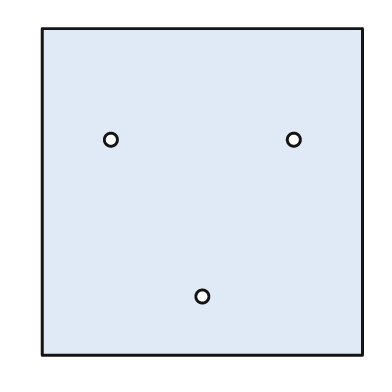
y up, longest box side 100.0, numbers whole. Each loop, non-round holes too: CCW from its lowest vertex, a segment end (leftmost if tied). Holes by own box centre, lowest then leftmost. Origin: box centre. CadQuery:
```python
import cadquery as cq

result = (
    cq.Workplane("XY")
    .moveTo(-49.0, -50.0)
    .lineTo(49.0, -50.0)
    .lineTo(49.0, 50.0)
    .lineTo(-49.0, 50.0)
    .close()
    .moveTo(0.0, -32.0)
    .circle(2.0)
    .moveTo(-28.0, 16.0)
    .circle(2.0)
    .moveTo(28.0, 16.0)
    .circle(2.0)
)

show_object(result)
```